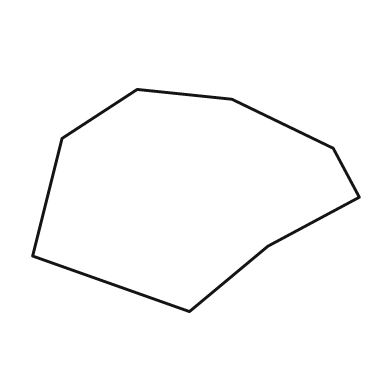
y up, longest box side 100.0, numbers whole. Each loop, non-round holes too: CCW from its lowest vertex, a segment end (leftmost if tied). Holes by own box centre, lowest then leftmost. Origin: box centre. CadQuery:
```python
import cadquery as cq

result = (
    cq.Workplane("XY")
    .moveTo(-2.0, -34.0)
    .lineTo(22.0, -14.0)
    .lineTo(50.0, 1.0)
    .lineTo(42.0, 16.0)
    .lineTo(11.0, 31.0)
    .lineTo(-18.0, 34.0)
    .lineTo(-41.0, 19.0)
    .lineTo(-50.0, -17.0)
    .close()
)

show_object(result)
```